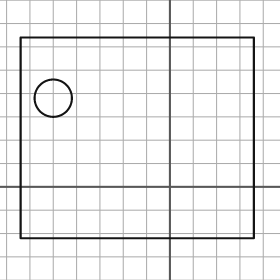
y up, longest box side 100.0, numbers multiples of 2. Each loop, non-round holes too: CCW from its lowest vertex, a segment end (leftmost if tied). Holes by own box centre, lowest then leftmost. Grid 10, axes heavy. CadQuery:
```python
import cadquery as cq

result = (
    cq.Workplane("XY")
    .moveTo(-64.0, -22.0)
    .lineTo(36.0, -22.0)
    .lineTo(36.0, 64.0)
    .lineTo(-64.0, 64.0)
    .close()
    .moveTo(-50.0, 38.0)
    .circle(8.0)
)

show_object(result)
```